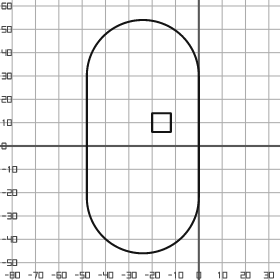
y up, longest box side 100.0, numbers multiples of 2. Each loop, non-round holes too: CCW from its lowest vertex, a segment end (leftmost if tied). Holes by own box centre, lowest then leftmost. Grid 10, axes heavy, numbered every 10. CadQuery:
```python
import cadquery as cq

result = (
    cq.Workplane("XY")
    .moveTo(-48.0, -22.0)
    .threePointArc((-24.0, -46.0), (0.0, -22.0))
    .lineTo(0.0, 30.0)
    .threePointArc((-24.0, 54.0), (-48.0, 30.0))
    .close()
    .moveTo(-20.0, 6.0)
    .lineTo(-12.0, 6.0)
    .lineTo(-12.0, 14.0)
    .lineTo(-20.0, 14.0)
    .close()
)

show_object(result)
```